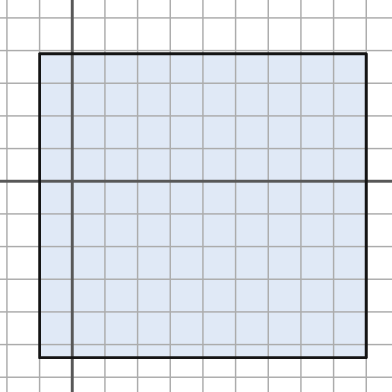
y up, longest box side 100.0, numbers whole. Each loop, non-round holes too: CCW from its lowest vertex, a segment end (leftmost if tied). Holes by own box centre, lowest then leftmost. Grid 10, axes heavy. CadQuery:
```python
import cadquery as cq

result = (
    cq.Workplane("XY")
    .moveTo(-10.0, -54.0)
    .lineTo(90.0, -54.0)
    .lineTo(90.0, 39.0)
    .lineTo(-10.0, 39.0)
    .close()
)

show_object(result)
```